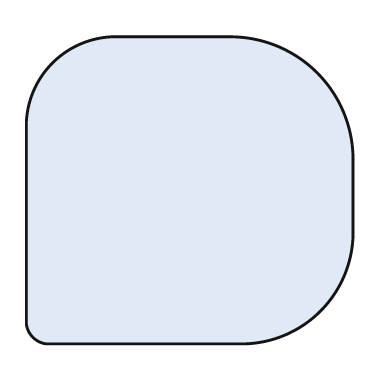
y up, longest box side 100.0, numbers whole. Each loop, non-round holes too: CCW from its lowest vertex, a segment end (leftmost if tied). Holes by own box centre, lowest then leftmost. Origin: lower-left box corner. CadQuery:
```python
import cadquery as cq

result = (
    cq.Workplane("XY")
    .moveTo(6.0, 0.0)
    .lineTo(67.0, 0.0)
    .threePointArc((90.0, 10.0), (100.0, 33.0))
    .lineTo(100.0, 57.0)
    .threePointArc((89.0, 83.0), (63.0, 94.0))
    .lineTo(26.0, 94.0)
    .threePointArc((8.0, 86.0), (0.0, 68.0))
    .lineTo(0.0, 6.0)
    .threePointArc((2.0, 2.0), (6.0, 0.0))
    .close()
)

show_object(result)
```